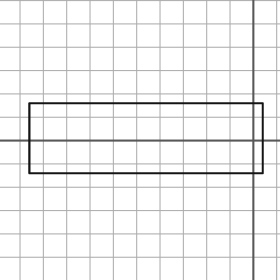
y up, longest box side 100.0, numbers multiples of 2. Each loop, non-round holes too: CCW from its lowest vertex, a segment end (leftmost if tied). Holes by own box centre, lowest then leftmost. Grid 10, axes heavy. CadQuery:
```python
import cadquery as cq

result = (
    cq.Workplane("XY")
    .moveTo(-96.0, -14.0)
    .lineTo(4.0, -14.0)
    .lineTo(4.0, 16.0)
    .lineTo(-96.0, 16.0)
    .close()
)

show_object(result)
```